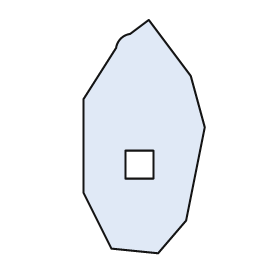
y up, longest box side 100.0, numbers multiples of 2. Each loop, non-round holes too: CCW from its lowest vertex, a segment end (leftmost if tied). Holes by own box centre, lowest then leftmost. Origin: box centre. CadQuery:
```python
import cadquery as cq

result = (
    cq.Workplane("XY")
    .moveTo(6.0, -50.0)
    .lineTo(18.0, -36.0)
    .lineTo(26.0, 4.0)
    .lineTo(20.0, 26.0)
    .lineTo(2.0, 50.0)
    .lineTo(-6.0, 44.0)
    .threePointArc((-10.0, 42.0), (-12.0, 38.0))
    .lineTo(-26.0, 16.0)
    .lineTo(-26.0, -24.0)
    .lineTo(-14.0, -48.0)
    .close()
    .moveTo(-8.0, -18.0)
    .lineTo(4.0, -18.0)
    .lineTo(4.0, -6.0)
    .lineTo(-8.0, -6.0)
    .close()
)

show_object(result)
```